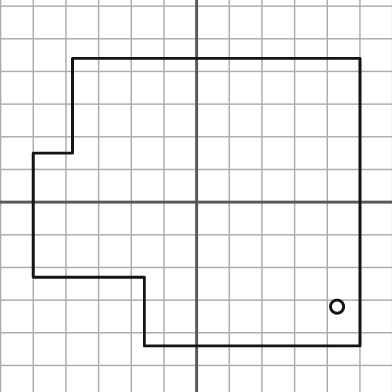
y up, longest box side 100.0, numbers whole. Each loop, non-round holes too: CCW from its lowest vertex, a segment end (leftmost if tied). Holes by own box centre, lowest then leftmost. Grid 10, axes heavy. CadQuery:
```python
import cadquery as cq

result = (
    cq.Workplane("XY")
    .moveTo(-16.0, -44.0)
    .lineTo(50.0, -44.0)
    .lineTo(50.0, 44.0)
    .lineTo(-38.0, 44.0)
    .lineTo(-38.0, 15.0)
    .lineTo(-50.0, 15.0)
    .lineTo(-50.0, -23.0)
    .lineTo(-16.0, -23.0)
    .close()
    .moveTo(43.0, -32.0)
    .circle(2.0)
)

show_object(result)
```